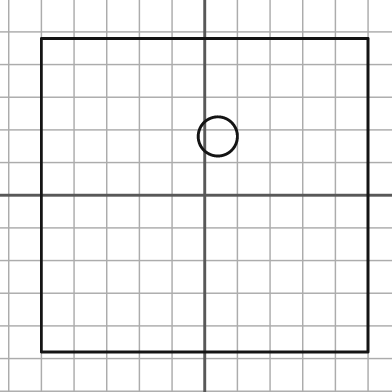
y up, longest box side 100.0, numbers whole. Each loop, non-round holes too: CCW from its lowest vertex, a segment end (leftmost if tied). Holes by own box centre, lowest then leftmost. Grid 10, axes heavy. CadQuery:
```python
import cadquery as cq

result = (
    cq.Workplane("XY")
    .moveTo(-50.0, -48.0)
    .lineTo(50.0, -48.0)
    .lineTo(50.0, 48.0)
    .lineTo(-50.0, 48.0)
    .close()
    .moveTo(4.0, 18.0)
    .circle(6.0)
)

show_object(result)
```